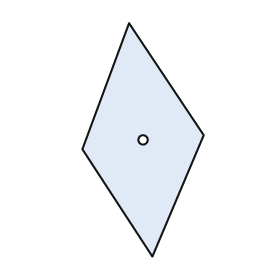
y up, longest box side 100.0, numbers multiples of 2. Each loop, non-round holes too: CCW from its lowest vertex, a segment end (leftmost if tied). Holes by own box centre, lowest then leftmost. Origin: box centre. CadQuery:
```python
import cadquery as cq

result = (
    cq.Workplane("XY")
    .moveTo(4.0, -50.0)
    .lineTo(26.0, 2.0)
    .lineTo(-6.0, 50.0)
    .lineTo(-26.0, -4.0)
    .close()
    .moveTo(0.0, 0.0)
    .circle(2.0)
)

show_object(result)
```